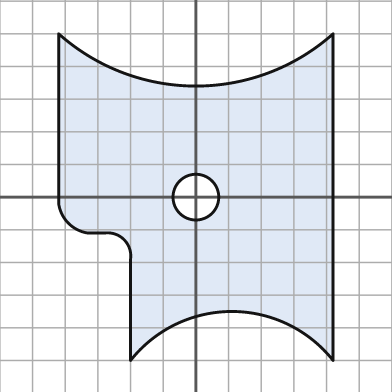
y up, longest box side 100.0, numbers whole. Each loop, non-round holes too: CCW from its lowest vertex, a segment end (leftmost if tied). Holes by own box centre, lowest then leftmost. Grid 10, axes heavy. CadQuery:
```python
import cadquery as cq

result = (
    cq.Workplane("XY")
    .moveTo(-20.0, -50.0)
    .threePointArc((11.0, -35.0), (42.0, -50.0))
    .lineTo(42.0, 50.0)
    .threePointArc((0.0, 34.0), (-42.0, 50.0))
    .lineTo(-42.0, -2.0)
    .threePointArc((-39.0, -8.0), (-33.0, -11.0))
    .lineTo(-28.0, -11.0)
    .threePointArc((-22.0, -13.0), (-20.0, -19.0))
    .close()
    .moveTo(0.0, 0.0)
    .circle(7.0)
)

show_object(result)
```